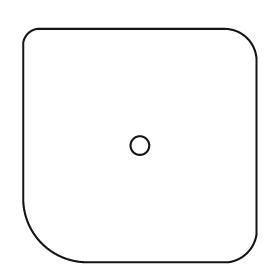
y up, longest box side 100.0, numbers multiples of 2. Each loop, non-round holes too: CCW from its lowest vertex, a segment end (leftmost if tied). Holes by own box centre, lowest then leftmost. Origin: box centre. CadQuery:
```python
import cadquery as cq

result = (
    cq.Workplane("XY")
    .moveTo(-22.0, -50.0)
    .lineTo(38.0, -50.0)
    .threePointArc((46.0, -46.0), (50.0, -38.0))
    .lineTo(50.0, 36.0)
    .threePointArc((46.0, 46.0), (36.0, 50.0))
    .lineTo(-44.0, 50.0)
    .threePointArc((-48.0, 48.0), (-50.0, 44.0))
    .lineTo(-50.0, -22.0)
    .threePointArc((-42.0, -42.0), (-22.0, -50.0))
    .close()
    .moveTo(0.0, 0.0)
    .circle(4.0)
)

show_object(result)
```